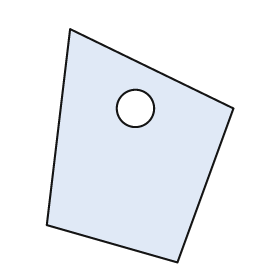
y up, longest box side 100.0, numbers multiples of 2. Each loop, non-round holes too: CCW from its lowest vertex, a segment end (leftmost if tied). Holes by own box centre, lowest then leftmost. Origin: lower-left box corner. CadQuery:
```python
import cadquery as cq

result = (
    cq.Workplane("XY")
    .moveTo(56.0, 0.0)
    .lineTo(80.0, 66.0)
    .lineTo(10.0, 100.0)
    .lineTo(0.0, 16.0)
    .close()
    .moveTo(38.0, 66.0)
    .circle(8.0)
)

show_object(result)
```